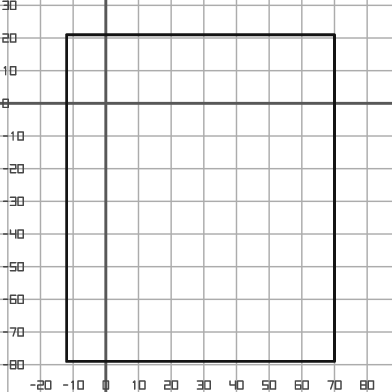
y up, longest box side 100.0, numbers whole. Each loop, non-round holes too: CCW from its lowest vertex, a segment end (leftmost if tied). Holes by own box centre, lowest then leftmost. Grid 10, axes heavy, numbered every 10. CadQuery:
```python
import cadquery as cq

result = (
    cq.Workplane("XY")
    .moveTo(-12.0, -79.0)
    .lineTo(70.0, -79.0)
    .lineTo(70.0, 21.0)
    .lineTo(-12.0, 21.0)
    .close()
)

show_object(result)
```